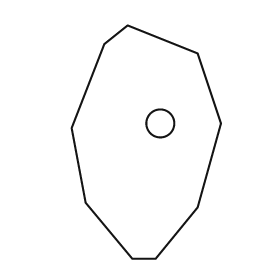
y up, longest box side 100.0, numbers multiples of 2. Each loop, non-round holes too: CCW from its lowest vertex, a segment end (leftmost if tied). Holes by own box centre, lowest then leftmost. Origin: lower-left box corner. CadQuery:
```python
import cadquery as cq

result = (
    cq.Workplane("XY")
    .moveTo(26.0, 0.0)
    .lineTo(36.0, 0.0)
    .lineTo(54.0, 22.0)
    .lineTo(64.0, 58.0)
    .lineTo(54.0, 88.0)
    .lineTo(24.0, 100.0)
    .lineTo(14.0, 92.0)
    .lineTo(0.0, 56.0)
    .lineTo(6.0, 24.0)
    .close()
    .moveTo(38.0, 58.0)
    .circle(6.0)
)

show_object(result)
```